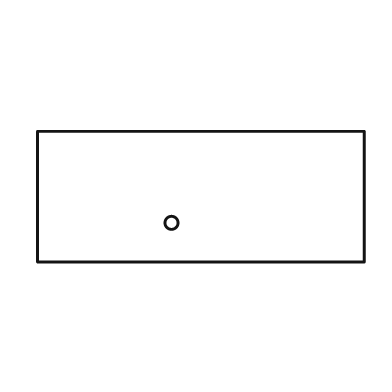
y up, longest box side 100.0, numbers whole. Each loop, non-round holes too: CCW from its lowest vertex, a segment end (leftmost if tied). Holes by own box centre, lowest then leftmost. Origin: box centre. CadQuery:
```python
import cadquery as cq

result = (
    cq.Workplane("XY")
    .moveTo(-50.0, -20.0)
    .lineTo(50.0, -20.0)
    .lineTo(50.0, 20.0)
    .lineTo(-50.0, 20.0)
    .close()
    .moveTo(-9.0, -8.0)
    .circle(2.0)
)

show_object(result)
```